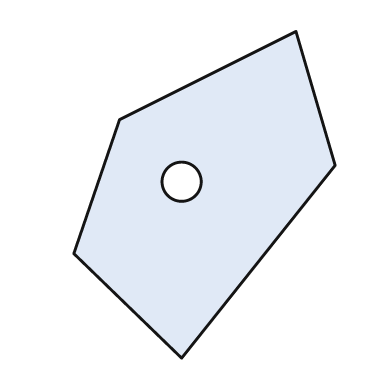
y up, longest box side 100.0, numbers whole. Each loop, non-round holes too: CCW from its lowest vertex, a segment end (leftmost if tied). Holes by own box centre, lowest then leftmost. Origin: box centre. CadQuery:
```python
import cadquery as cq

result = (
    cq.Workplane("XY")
    .moveTo(-7.0, -50.0)
    .lineTo(40.0, 9.0)
    .lineTo(28.0, 50.0)
    .lineTo(-26.0, 23.0)
    .lineTo(-40.0, -18.0)
    .close()
    .moveTo(-7.0, 4.0)
    .circle(6.0)
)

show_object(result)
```